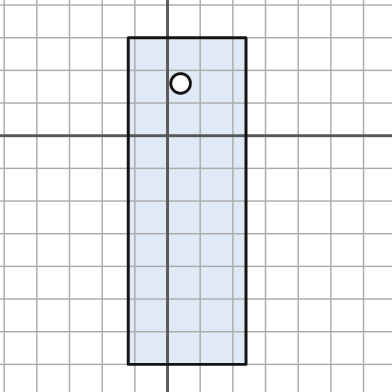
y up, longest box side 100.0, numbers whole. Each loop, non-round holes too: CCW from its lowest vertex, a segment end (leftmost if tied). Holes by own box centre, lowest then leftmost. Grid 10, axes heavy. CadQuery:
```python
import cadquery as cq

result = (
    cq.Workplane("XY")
    .moveTo(-12.0, -70.0)
    .lineTo(24.0, -70.0)
    .lineTo(24.0, 30.0)
    .lineTo(-12.0, 30.0)
    .close()
    .moveTo(4.0, 16.0)
    .circle(3.0)
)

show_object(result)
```